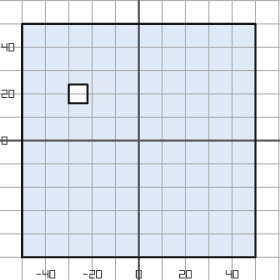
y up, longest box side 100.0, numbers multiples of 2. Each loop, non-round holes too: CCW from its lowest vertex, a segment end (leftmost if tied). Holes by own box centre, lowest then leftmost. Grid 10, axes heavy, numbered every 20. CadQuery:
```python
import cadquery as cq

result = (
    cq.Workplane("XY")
    .moveTo(-50.0, -50.0)
    .lineTo(50.0, -50.0)
    .lineTo(50.0, 50.0)
    .lineTo(-50.0, 50.0)
    .close()
    .moveTo(-30.0, 16.0)
    .lineTo(-22.0, 16.0)
    .lineTo(-22.0, 24.0)
    .lineTo(-30.0, 24.0)
    .close()
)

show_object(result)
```